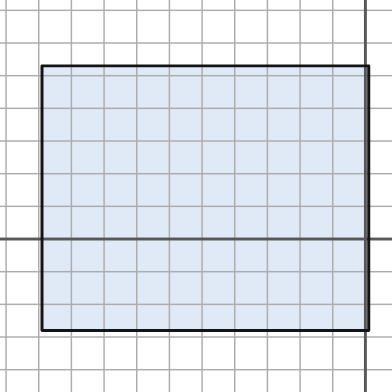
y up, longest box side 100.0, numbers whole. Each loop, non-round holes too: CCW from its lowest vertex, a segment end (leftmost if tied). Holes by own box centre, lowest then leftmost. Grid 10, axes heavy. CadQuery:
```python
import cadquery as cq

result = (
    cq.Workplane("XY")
    .moveTo(-99.0, -28.0)
    .lineTo(1.0, -28.0)
    .lineTo(1.0, 53.0)
    .lineTo(-99.0, 53.0)
    .close()
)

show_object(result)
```